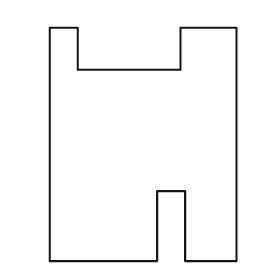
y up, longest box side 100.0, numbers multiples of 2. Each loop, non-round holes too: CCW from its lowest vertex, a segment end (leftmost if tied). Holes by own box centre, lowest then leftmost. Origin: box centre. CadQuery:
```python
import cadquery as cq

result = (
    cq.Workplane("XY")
    .moveTo(-40.0, -50.0)
    .lineTo(6.0, -50.0)
    .lineTo(6.0, -20.0)
    .lineTo(18.0, -20.0)
    .lineTo(18.0, -50.0)
    .lineTo(40.0, -50.0)
    .lineTo(40.0, 50.0)
    .lineTo(16.0, 50.0)
    .lineTo(16.0, 32.0)
    .lineTo(-28.0, 32.0)
    .lineTo(-28.0, 50.0)
    .lineTo(-40.0, 50.0)
    .close()
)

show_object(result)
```